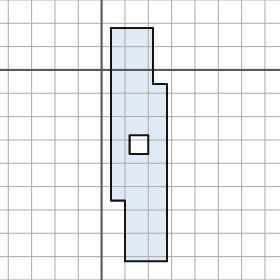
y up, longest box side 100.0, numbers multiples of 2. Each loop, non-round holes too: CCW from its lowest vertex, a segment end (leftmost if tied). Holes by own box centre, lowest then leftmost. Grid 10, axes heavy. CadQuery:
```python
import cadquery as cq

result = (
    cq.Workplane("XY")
    .moveTo(10.0, -82.0)
    .lineTo(28.0, -82.0)
    .lineTo(28.0, -6.0)
    .lineTo(22.0, -6.0)
    .lineTo(22.0, 18.0)
    .lineTo(4.0, 18.0)
    .lineTo(4.0, -56.0)
    .lineTo(10.0, -56.0)
    .close()
    .moveTo(12.0, -36.0)
    .lineTo(20.0, -36.0)
    .lineTo(20.0, -28.0)
    .lineTo(12.0, -28.0)
    .close()
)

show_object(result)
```